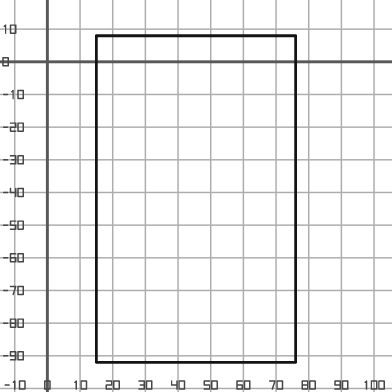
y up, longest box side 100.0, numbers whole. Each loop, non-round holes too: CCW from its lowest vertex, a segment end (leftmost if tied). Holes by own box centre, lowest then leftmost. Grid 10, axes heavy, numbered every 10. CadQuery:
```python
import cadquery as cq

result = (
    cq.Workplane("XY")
    .moveTo(15.0, -92.0)
    .lineTo(76.0, -92.0)
    .lineTo(76.0, 8.0)
    .lineTo(15.0, 8.0)
    .close()
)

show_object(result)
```